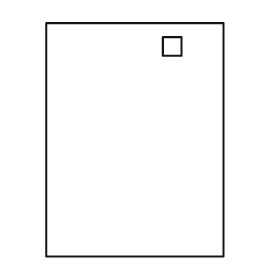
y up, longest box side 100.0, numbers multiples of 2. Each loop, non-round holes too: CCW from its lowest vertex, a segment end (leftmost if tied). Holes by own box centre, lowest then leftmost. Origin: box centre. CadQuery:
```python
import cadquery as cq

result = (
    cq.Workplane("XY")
    .moveTo(-38.0, -50.0)
    .lineTo(38.0, -50.0)
    .lineTo(38.0, 50.0)
    .lineTo(-38.0, 50.0)
    .close()
    .moveTo(12.0, 36.0)
    .lineTo(20.0, 36.0)
    .lineTo(20.0, 44.0)
    .lineTo(12.0, 44.0)
    .close()
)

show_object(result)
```